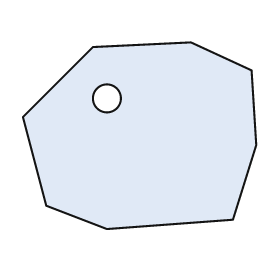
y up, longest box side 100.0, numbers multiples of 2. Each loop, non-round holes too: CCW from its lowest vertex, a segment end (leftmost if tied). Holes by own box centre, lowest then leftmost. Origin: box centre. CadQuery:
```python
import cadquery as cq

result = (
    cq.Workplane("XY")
    .moveTo(-14.0, -40.0)
    .lineTo(40.0, -36.0)
    .lineTo(50.0, -4.0)
    .lineTo(48.0, 28.0)
    .lineTo(22.0, 40.0)
    .lineTo(-20.0, 38.0)
    .lineTo(-50.0, 8.0)
    .lineTo(-40.0, -30.0)
    .close()
    .moveTo(-14.0, 16.0)
    .circle(6.0)
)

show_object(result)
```